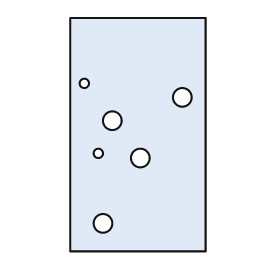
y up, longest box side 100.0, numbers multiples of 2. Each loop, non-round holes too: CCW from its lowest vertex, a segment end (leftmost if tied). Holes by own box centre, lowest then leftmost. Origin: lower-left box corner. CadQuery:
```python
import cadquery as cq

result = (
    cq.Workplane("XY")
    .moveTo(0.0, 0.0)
    .lineTo(58.0, 0.0)
    .lineTo(58.0, 100.0)
    .lineTo(0.0, 100.0)
    .close()
    .moveTo(14.0, 12.0)
    .circle(4.0)
    .moveTo(30.0, 40.0)
    .circle(4.0)
    .moveTo(12.0, 42.0)
    .circle(2.0)
    .moveTo(18.0, 56.0)
    .circle(4.0)
    .moveTo(48.0, 66.0)
    .circle(4.0)
    .moveTo(6.0, 72.0)
    .circle(2.0)
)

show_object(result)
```